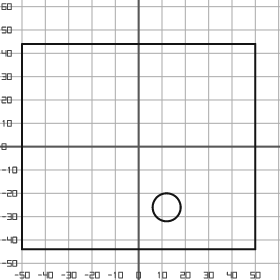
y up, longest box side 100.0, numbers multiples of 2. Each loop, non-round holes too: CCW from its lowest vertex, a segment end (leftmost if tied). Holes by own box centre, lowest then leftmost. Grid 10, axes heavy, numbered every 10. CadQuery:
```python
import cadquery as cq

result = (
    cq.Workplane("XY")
    .moveTo(-50.0, -44.0)
    .lineTo(50.0, -44.0)
    .lineTo(50.0, 44.0)
    .lineTo(-50.0, 44.0)
    .close()
    .moveTo(12.0, -26.0)
    .circle(6.0)
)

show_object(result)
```